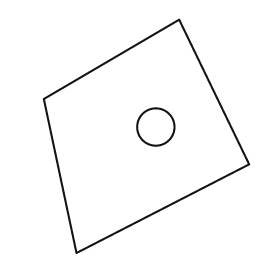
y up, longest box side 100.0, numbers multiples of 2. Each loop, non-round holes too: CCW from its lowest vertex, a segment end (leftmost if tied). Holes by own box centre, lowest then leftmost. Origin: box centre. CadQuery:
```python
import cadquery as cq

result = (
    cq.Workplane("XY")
    .moveTo(-30.0, -50.0)
    .lineTo(44.0, -12.0)
    .lineTo(14.0, 50.0)
    .lineTo(-44.0, 16.0)
    .close()
    .moveTo(4.0, 4.0)
    .circle(8.0)
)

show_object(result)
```